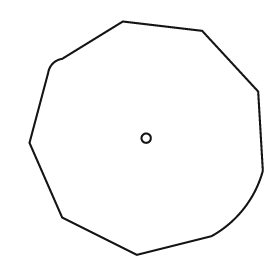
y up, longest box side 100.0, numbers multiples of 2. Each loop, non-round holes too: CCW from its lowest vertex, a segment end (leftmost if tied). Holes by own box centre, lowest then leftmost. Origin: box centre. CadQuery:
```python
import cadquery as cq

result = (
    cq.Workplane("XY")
    .moveTo(-4.0, -50.0)
    .lineTo(28.0, -42.0)
    .threePointArc((42.0, -30.0), (50.0, -14.0))
    .lineTo(48.0, 20.0)
    .lineTo(24.0, 46.0)
    .lineTo(-10.0, 50.0)
    .lineTo(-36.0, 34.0)
    .threePointArc((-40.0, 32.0), (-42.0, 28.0))
    .lineTo(-50.0, -2.0)
    .lineTo(-36.0, -34.0)
    .close()
    .moveTo(0.0, 0.0)
    .circle(2.0)
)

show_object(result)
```